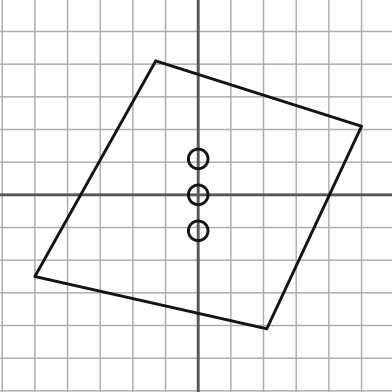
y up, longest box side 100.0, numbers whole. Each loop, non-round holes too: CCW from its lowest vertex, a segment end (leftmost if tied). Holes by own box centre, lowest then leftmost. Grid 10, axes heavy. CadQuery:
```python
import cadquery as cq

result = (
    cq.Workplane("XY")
    .moveTo(21.0, -41.0)
    .lineTo(50.0, 21.0)
    .lineTo(-13.0, 41.0)
    .lineTo(-50.0, -25.0)
    .close()
    .moveTo(0.0, -11.0)
    .circle(3.0)
    .moveTo(0.0, 0.0)
    .circle(3.0)
    .moveTo(0.0, 11.0)
    .circle(3.0)
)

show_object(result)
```